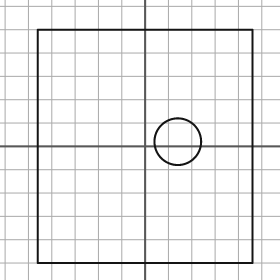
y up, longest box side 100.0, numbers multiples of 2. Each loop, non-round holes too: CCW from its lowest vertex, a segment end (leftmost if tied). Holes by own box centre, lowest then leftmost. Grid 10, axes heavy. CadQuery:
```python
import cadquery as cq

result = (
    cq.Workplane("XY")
    .moveTo(-46.0, -50.0)
    .lineTo(46.0, -50.0)
    .lineTo(46.0, 50.0)
    .lineTo(-46.0, 50.0)
    .close()
    .moveTo(14.0, 2.0)
    .circle(10.0)
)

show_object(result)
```